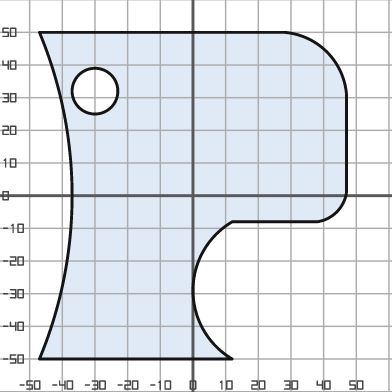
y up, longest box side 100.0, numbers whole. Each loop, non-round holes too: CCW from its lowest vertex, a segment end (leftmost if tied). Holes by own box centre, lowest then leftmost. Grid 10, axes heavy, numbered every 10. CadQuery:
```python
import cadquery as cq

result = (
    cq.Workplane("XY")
    .moveTo(-47.0, -50.0)
    .lineTo(12.0, -50.0)
    .threePointArc((0.0, -29.0), (12.0, -8.0))
    .lineTo(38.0, -8.0)
    .threePointArc((44.0, -5.0), (47.0, 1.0))
    .lineTo(47.0, 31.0)
    .threePointArc((41.0, 44.0), (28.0, 50.0))
    .lineTo(-47.0, 50.0)
    .threePointArc((-37.0, 0.0), (-47.0, -50.0))
    .close()
    .moveTo(-30.0, 32.0)
    .circle(7.0)
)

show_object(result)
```